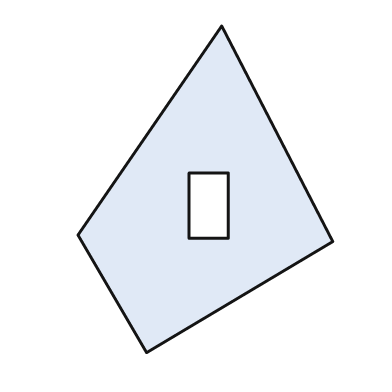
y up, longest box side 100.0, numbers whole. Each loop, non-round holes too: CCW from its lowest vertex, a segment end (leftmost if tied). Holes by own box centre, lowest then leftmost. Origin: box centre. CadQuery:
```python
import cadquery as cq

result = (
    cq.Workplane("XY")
    .moveTo(-18.0, -50.0)
    .lineTo(39.0, -16.0)
    .lineTo(5.0, 50.0)
    .lineTo(-39.0, -14.0)
    .close()
    .moveTo(-5.0, -15.0)
    .lineTo(7.0, -15.0)
    .lineTo(7.0, 5.0)
    .lineTo(-5.0, 5.0)
    .close()
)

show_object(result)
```